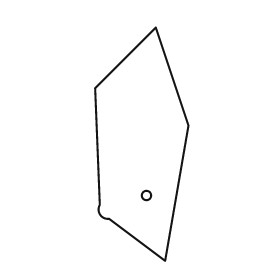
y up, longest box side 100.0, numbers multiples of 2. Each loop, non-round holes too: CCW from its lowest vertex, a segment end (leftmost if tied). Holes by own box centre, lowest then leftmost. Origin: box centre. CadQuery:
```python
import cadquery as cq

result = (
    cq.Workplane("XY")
    .moveTo(10.0, -50.0)
    .lineTo(20.0, 8.0)
    .lineTo(6.0, 50.0)
    .lineTo(-20.0, 24.0)
    .lineTo(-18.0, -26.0)
    .threePointArc((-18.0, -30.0), (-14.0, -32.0))
    .close()
    .moveTo(2.0, -22.0)
    .circle(2.0)
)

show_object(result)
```